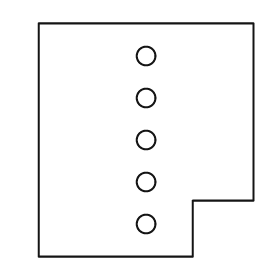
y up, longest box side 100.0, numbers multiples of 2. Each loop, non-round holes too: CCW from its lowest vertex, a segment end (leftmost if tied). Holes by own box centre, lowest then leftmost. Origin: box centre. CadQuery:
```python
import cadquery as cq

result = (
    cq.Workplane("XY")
    .moveTo(-46.0, -50.0)
    .lineTo(20.0, -50.0)
    .lineTo(20.0, -26.0)
    .lineTo(46.0, -26.0)
    .lineTo(46.0, 50.0)
    .lineTo(-46.0, 50.0)
    .close()
    .moveTo(0.0, -36.0)
    .circle(4.0)
    .moveTo(0.0, -18.0)
    .circle(4.0)
    .moveTo(0.0, 0.0)
    .circle(4.0)
    .moveTo(0.0, 18.0)
    .circle(4.0)
    .moveTo(0.0, 36.0)
    .circle(4.0)
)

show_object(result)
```